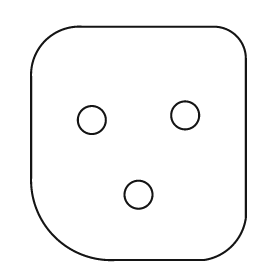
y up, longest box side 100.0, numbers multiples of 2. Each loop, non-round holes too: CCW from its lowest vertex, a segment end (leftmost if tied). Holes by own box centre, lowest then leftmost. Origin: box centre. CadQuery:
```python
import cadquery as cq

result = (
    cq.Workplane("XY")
    .moveTo(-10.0, -50.0)
    .lineTo(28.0, -50.0)
    .threePointArc((40.0, -44.0), (46.0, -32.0))
    .lineTo(46.0, 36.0)
    .threePointArc((42.0, 46.0), (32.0, 50.0))
    .lineTo(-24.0, 50.0)
    .threePointArc((-40.0, 44.0), (-46.0, 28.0))
    .lineTo(-46.0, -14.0)
    .threePointArc((-36.0, -40.0), (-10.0, -50.0))
    .close()
    .moveTo(0.0, -22.0)
    .circle(6.0)
    .moveTo(-20.0, 10.0)
    .circle(6.0)
    .moveTo(20.0, 12.0)
    .circle(6.0)
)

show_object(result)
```